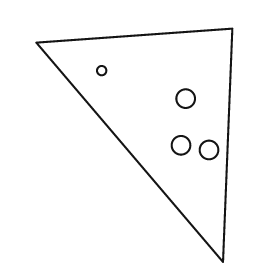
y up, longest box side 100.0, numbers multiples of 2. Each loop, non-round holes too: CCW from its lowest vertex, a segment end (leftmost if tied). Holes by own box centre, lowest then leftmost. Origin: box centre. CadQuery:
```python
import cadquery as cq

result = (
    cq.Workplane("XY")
    .moveTo(38.0, -50.0)
    .lineTo(42.0, 50.0)
    .lineTo(-42.0, 44.0)
    .close()
    .moveTo(32.0, -2.0)
    .circle(4.0)
    .moveTo(20.0, 0.0)
    .circle(4.0)
    .moveTo(22.0, 20.0)
    .circle(4.0)
    .moveTo(-14.0, 32.0)
    .circle(2.0)
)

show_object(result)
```